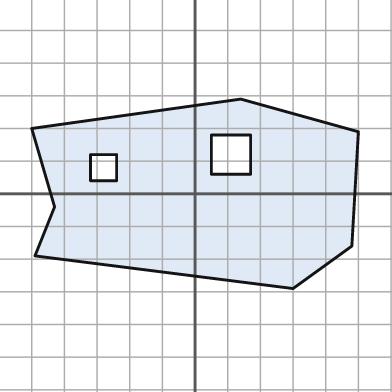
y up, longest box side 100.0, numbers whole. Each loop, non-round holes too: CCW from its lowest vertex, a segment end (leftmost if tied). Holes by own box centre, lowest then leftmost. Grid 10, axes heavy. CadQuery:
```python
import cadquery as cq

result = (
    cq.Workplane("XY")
    .moveTo(30.0, -29.0)
    .lineTo(48.0, -16.0)
    .lineTo(50.0, 19.0)
    .lineTo(14.0, 29.0)
    .lineTo(-50.0, 20.0)
    .lineTo(-43.0, -4.0)
    .lineTo(-49.0, -19.0)
    .close()
    .moveTo(-32.0, 4.0)
    .lineTo(-24.0, 4.0)
    .lineTo(-24.0, 12.0)
    .lineTo(-32.0, 12.0)
    .close()
    .moveTo(5.0, 6.0)
    .lineTo(17.0, 6.0)
    .lineTo(17.0, 18.0)
    .lineTo(5.0, 18.0)
    .close()
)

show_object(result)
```